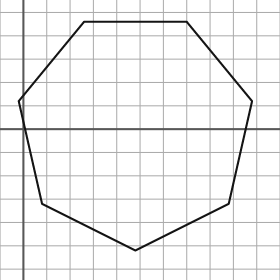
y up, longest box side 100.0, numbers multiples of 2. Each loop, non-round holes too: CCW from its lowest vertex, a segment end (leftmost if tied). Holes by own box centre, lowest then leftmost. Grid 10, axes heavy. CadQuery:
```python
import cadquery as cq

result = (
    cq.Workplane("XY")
    .moveTo(48.0, -52.0)
    .lineTo(88.0, -32.0)
    .lineTo(98.0, 12.0)
    .lineTo(70.0, 46.0)
    .lineTo(26.0, 46.0)
    .lineTo(-2.0, 12.0)
    .lineTo(8.0, -32.0)
    .close()
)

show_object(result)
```